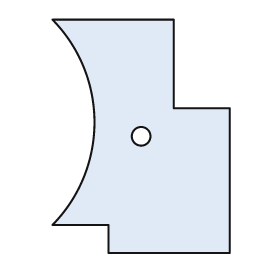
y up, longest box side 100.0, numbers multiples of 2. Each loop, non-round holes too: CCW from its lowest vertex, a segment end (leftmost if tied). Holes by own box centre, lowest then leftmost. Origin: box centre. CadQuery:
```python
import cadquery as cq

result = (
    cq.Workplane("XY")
    .moveTo(-14.0, -50.0)
    .lineTo(38.0, -50.0)
    .lineTo(38.0, 12.0)
    .lineTo(14.0, 12.0)
    .lineTo(14.0, 50.0)
    .lineTo(-38.0, 50.0)
    .threePointArc((-20.0, 6.0), (-38.0, -38.0))
    .lineTo(-14.0, -38.0)
    .close()
    .moveTo(0.0, 0.0)
    .circle(4.0)
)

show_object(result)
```